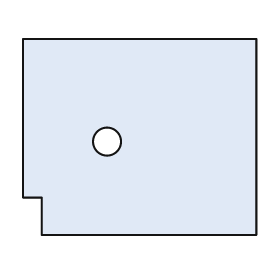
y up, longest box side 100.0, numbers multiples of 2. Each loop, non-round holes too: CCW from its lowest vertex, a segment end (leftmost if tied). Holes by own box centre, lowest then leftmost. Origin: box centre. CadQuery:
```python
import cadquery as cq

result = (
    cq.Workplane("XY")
    .moveTo(-42.0, -42.0)
    .lineTo(50.0, -42.0)
    .lineTo(50.0, 42.0)
    .lineTo(-50.0, 42.0)
    .lineTo(-50.0, -26.0)
    .lineTo(-42.0, -26.0)
    .close()
    .moveTo(-14.0, -2.0)
    .circle(6.0)
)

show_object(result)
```